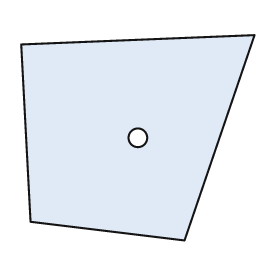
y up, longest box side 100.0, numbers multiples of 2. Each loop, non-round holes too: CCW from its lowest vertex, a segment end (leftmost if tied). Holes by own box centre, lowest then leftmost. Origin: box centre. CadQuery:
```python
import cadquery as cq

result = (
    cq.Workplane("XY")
    .moveTo(20.0, -44.0)
    .lineTo(50.0, 44.0)
    .lineTo(-50.0, 40.0)
    .lineTo(-46.0, -36.0)
    .close()
    .moveTo(0.0, 0.0)
    .circle(4.0)
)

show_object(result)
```